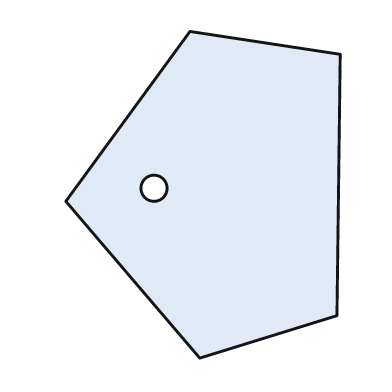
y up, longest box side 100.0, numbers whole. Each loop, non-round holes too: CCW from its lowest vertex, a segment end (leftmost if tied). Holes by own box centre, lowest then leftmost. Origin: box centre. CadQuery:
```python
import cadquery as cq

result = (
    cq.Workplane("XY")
    .moveTo(-1.0, -50.0)
    .lineTo(41.0, -37.0)
    .lineTo(42.0, 43.0)
    .lineTo(-4.0, 50.0)
    .lineTo(-42.0, -2.0)
    .close()
    .moveTo(-15.0, 2.0)
    .circle(4.0)
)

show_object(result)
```